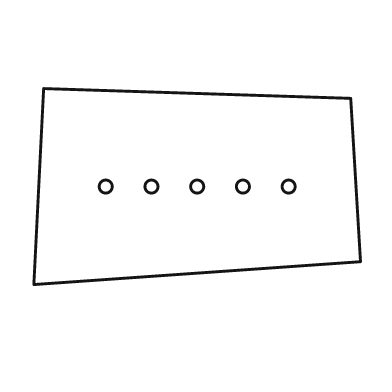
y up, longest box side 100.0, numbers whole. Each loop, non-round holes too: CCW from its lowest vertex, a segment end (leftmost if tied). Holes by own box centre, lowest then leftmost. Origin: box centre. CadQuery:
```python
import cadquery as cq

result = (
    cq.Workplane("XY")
    .moveTo(-50.0, -30.0)
    .lineTo(50.0, -23.0)
    .lineTo(47.0, 27.0)
    .lineTo(-47.0, 30.0)
    .close()
    .moveTo(-28.0, 0.0)
    .circle(2.0)
    .moveTo(-14.0, 0.0)
    .circle(2.0)
    .moveTo(0.0, 0.0)
    .circle(2.0)
    .moveTo(14.0, 0.0)
    .circle(2.0)
    .moveTo(28.0, 0.0)
    .circle(2.0)
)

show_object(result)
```